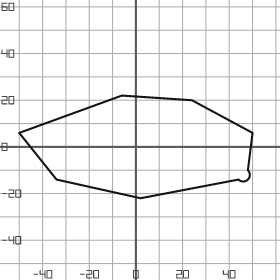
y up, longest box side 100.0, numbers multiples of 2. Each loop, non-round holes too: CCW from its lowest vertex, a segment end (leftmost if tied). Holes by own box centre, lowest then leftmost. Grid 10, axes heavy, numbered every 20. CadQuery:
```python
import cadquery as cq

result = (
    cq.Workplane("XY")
    .moveTo(2.0, -22.0)
    .lineTo(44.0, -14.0)
    .threePointArc((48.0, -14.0), (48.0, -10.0))
    .lineTo(50.0, 6.0)
    .lineTo(24.0, 20.0)
    .lineTo(-6.0, 22.0)
    .lineTo(-50.0, 6.0)
    .lineTo(-34.0, -14.0)
    .close()
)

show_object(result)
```